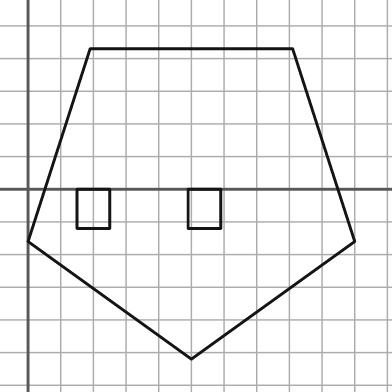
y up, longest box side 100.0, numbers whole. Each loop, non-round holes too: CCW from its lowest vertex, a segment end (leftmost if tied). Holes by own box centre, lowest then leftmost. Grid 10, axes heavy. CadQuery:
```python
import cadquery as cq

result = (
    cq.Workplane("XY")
    .moveTo(50.0, -52.0)
    .lineTo(100.0, -16.0)
    .lineTo(81.0, 43.0)
    .lineTo(19.0, 43.0)
    .lineTo(0.0, -16.0)
    .close()
    .moveTo(15.0, -12.0)
    .lineTo(25.0, -12.0)
    .lineTo(25.0, 0.0)
    .lineTo(15.0, 0.0)
    .close()
    .moveTo(49.0, -12.0)
    .lineTo(59.0, -12.0)
    .lineTo(59.0, 0.0)
    .lineTo(49.0, 0.0)
    .close()
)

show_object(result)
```